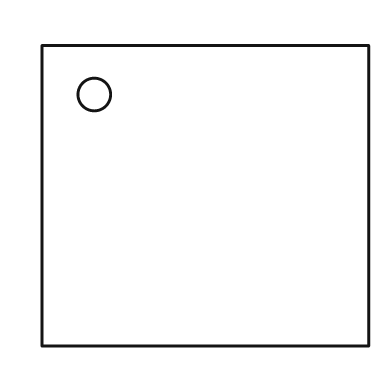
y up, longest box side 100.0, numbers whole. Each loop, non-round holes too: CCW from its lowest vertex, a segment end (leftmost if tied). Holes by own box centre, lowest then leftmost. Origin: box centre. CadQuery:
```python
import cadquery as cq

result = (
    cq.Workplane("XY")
    .moveTo(-50.0, -46.0)
    .lineTo(50.0, -46.0)
    .lineTo(50.0, 46.0)
    .lineTo(-50.0, 46.0)
    .close()
    .moveTo(-34.0, 31.0)
    .circle(5.0)
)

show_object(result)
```